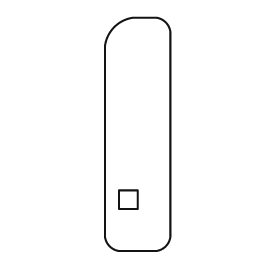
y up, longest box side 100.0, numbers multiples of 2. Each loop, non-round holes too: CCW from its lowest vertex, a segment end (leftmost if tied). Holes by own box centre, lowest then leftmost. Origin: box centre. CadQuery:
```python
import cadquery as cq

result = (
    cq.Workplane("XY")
    .moveTo(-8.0, -50.0)
    .lineTo(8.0, -50.0)
    .threePointArc((12.0, -48.0), (14.0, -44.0))
    .lineTo(14.0, 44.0)
    .threePointArc((12.0, 48.0), (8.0, 50.0))
    .lineTo(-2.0, 50.0)
    .threePointArc((-10.0, 46.0), (-14.0, 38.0))
    .lineTo(-14.0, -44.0)
    .threePointArc((-12.0, -48.0), (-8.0, -50.0))
    .close()
    .moveTo(-8.0, -32.0)
    .lineTo(0.0, -32.0)
    .lineTo(0.0, -24.0)
    .lineTo(-8.0, -24.0)
    .close()
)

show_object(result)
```